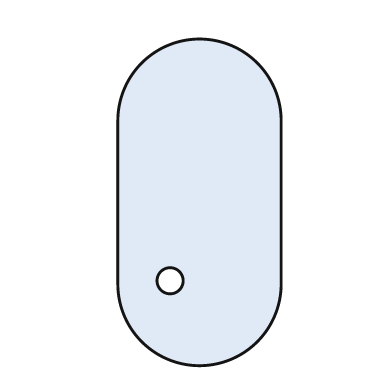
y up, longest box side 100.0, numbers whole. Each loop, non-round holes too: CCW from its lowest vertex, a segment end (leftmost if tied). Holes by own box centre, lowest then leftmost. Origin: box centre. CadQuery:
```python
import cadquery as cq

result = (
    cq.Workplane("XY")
    .moveTo(-25.0, -25.0)
    .threePointArc((0.0, -50.0), (25.0, -25.0))
    .lineTo(25.0, 25.0)
    .threePointArc((0.0, 50.0), (-25.0, 25.0))
    .close()
    .moveTo(-9.0, -24.0)
    .circle(4.0)
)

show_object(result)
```